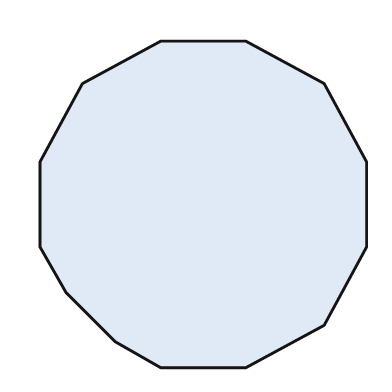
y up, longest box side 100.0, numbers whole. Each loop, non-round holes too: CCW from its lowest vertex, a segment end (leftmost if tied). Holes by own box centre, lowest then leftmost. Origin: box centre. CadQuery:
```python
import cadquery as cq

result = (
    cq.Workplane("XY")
    .moveTo(-13.0, -50.0)
    .lineTo(13.0, -50.0)
    .lineTo(37.0, -37.0)
    .lineTo(50.0, -13.0)
    .lineTo(50.0, 13.0)
    .lineTo(37.0, 37.0)
    .lineTo(13.0, 50.0)
    .lineTo(-13.0, 50.0)
    .lineTo(-37.0, 37.0)
    .lineTo(-50.0, 13.0)
    .lineTo(-50.0, -13.0)
    .lineTo(-42.0, -27.0)
    .lineTo(-27.0, -42.0)
    .close()
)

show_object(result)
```